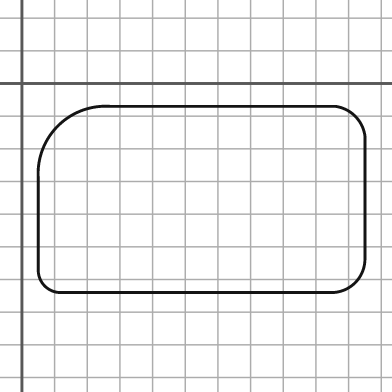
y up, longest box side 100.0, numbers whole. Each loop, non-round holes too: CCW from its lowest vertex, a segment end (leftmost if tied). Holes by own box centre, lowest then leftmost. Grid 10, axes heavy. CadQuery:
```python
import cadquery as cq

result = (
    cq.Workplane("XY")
    .moveTo(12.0, -64.0)
    .lineTo(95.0, -64.0)
    .threePointArc((102.0, -61.0), (105.0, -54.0))
    .lineTo(105.0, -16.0)
    .threePointArc((102.0, -10.0), (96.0, -7.0))
    .lineTo(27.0, -7.0)
    .threePointArc((11.0, -13.0), (5.0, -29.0))
    .lineTo(5.0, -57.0)
    .threePointArc((7.0, -62.0), (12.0, -64.0))
    .close()
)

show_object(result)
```